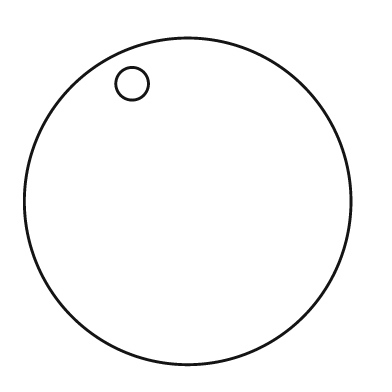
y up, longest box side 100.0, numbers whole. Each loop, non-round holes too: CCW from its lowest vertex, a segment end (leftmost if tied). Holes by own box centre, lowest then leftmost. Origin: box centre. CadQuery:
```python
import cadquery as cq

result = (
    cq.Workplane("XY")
    .moveTo(0.0, 0.0)
    .circle(50.0)
    .moveTo(-17.0, 36.0)
    .circle(5.0)
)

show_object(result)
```